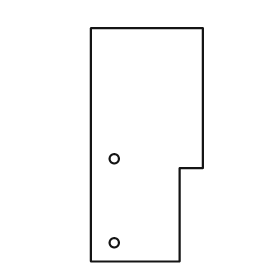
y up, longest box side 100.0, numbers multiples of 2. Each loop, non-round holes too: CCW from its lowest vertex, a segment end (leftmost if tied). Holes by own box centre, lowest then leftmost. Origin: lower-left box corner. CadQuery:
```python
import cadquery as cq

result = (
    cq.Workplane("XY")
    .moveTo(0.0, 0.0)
    .lineTo(38.0, 0.0)
    .lineTo(38.0, 40.0)
    .lineTo(48.0, 40.0)
    .lineTo(48.0, 100.0)
    .lineTo(0.0, 100.0)
    .close()
    .moveTo(10.0, 8.0)
    .circle(2.0)
    .moveTo(10.0, 44.0)
    .circle(2.0)
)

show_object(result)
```